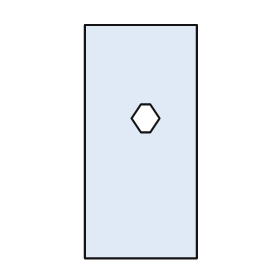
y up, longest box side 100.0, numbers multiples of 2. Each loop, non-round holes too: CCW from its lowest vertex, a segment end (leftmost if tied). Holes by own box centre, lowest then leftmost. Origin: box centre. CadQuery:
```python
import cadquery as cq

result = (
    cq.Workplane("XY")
    .moveTo(-24.0, -50.0)
    .lineTo(24.0, -50.0)
    .lineTo(24.0, 50.0)
    .lineTo(-24.0, 50.0)
    .close()
    .moveTo(0.0, 4.0)
    .lineTo(4.0, 4.0)
    .lineTo(8.0, 10.0)
    .lineTo(4.0, 16.0)
    .lineTo(0.0, 16.0)
    .lineTo(-4.0, 10.0)
    .close()
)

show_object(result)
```